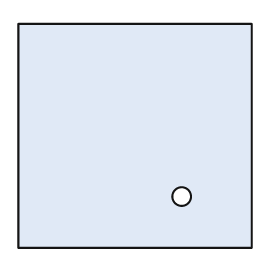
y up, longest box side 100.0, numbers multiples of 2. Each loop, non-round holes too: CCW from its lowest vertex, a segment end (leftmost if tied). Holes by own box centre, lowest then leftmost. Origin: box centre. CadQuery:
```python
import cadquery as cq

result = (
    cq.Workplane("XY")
    .moveTo(-50.0, -48.0)
    .lineTo(50.0, -48.0)
    .lineTo(50.0, 48.0)
    .lineTo(-50.0, 48.0)
    .close()
    .moveTo(20.0, -26.0)
    .circle(4.0)
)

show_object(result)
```